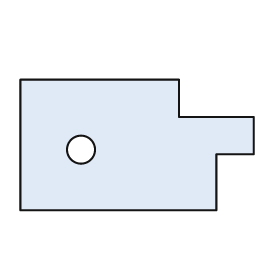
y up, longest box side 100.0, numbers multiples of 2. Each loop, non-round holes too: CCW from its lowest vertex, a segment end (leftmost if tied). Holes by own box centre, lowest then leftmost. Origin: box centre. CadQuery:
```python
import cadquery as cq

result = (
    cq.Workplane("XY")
    .moveTo(-50.0, -28.0)
    .lineTo(34.0, -28.0)
    .lineTo(34.0, -4.0)
    .lineTo(50.0, -4.0)
    .lineTo(50.0, 12.0)
    .lineTo(18.0, 12.0)
    .lineTo(18.0, 28.0)
    .lineTo(-50.0, 28.0)
    .close()
    .moveTo(-24.0, -2.0)
    .circle(6.0)
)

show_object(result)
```